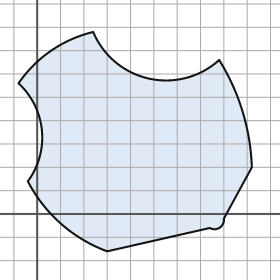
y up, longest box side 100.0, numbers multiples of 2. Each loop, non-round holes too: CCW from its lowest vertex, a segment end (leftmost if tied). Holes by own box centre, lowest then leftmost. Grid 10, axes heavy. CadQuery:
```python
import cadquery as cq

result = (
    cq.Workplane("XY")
    .moveTo(30.0, -16.0)
    .lineTo(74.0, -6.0)
    .threePointArc((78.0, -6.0), (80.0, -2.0))
    .lineTo(92.0, 20.0)
    .threePointArc((88.0, 44.0), (78.0, 66.0))
    .threePointArc((48.0, 58.0), (24.0, 78.0))
    .threePointArc((6.0, 70.0), (-8.0, 56.0))
    .threePointArc((2.0, 36.0), (-4.0, 14.0))
    .threePointArc((10.0, -4.0), (30.0, -16.0))
    .close()
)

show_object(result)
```